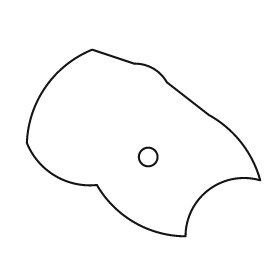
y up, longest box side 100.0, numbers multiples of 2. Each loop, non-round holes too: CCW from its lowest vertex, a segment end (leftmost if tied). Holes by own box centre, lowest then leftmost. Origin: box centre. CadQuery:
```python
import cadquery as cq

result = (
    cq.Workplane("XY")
    .moveTo(18.0, -40.0)
    .threePointArc((28.0, -20.0), (50.0, -16.0))
    .threePointArc((42.0, 0.0), (28.0, 12.0))
    .lineTo(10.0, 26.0)
    .threePointArc((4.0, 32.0), (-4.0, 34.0))
    .lineTo(-22.0, 40.0)
    .threePointArc((-42.0, 24.0), (-50.0, 0.0))
    .threePointArc((-38.0, -14.0), (-20.0, -18.0))
    .threePointArc((-4.0, -34.0), (18.0, -40.0))
    .close()
    .moveTo(2.0, -6.0)
    .circle(4.0)
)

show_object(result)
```